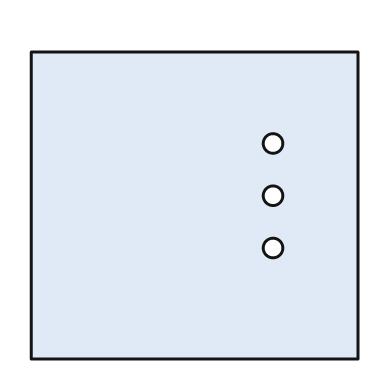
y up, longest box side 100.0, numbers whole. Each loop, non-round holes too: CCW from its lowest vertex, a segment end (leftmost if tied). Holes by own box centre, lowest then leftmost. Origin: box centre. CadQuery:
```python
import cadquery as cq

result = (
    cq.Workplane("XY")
    .moveTo(-50.0, -47.0)
    .lineTo(50.0, -47.0)
    .lineTo(50.0, 47.0)
    .lineTo(-50.0, 47.0)
    .close()
    .moveTo(24.0, -13.0)
    .circle(3.0)
    .moveTo(24.0, 3.0)
    .circle(3.0)
    .moveTo(24.0, 19.0)
    .circle(3.0)
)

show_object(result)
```